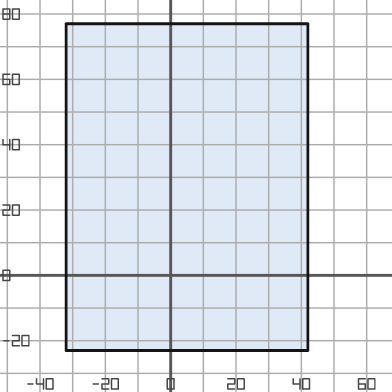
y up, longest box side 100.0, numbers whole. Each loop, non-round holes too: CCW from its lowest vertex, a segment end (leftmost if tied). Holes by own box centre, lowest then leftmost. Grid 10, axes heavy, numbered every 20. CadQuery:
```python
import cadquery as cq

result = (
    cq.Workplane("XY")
    .moveTo(-32.0, -23.0)
    .lineTo(42.0, -23.0)
    .lineTo(42.0, 77.0)
    .lineTo(-32.0, 77.0)
    .close()
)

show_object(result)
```